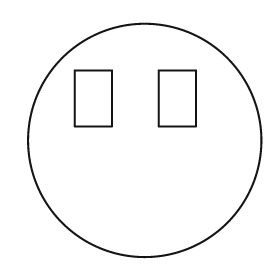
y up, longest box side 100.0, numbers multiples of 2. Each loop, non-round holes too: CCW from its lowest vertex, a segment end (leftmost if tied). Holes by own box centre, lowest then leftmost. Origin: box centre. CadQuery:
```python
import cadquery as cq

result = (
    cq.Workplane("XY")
    .moveTo(0.0, 0.0)
    .circle(50.0)
    .moveTo(-30.0, 6.0)
    .lineTo(-14.0, 6.0)
    .lineTo(-14.0, 30.0)
    .lineTo(-30.0, 30.0)
    .close()
    .moveTo(6.0, 6.0)
    .lineTo(22.0, 6.0)
    .lineTo(22.0, 30.0)
    .lineTo(6.0, 30.0)
    .close()
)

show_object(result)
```